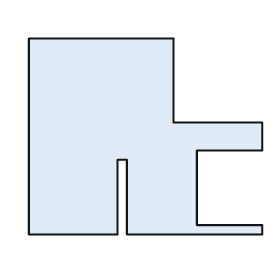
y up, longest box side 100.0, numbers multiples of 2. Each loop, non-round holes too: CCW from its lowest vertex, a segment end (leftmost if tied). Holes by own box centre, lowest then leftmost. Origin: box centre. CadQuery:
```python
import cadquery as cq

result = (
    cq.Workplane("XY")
    .moveTo(-50.0, -42.0)
    .lineTo(-12.0, -42.0)
    .lineTo(-12.0, -10.0)
    .lineTo(-8.0, -10.0)
    .lineTo(-8.0, -42.0)
    .lineTo(50.0, -42.0)
    .lineTo(50.0, -38.0)
    .lineTo(22.0, -38.0)
    .lineTo(22.0, -6.0)
    .lineTo(50.0, -6.0)
    .lineTo(50.0, 6.0)
    .lineTo(12.0, 6.0)
    .lineTo(12.0, 42.0)
    .lineTo(-50.0, 42.0)
    .close()
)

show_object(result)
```